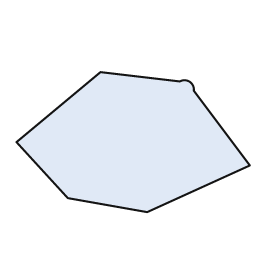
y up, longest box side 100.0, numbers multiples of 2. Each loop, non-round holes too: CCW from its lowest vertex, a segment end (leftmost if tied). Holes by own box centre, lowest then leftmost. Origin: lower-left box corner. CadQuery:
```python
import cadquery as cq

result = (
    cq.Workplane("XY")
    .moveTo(56.0, 0.0)
    .lineTo(100.0, 20.0)
    .lineTo(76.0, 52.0)
    .threePointArc((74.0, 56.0), (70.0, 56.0))
    .lineTo(36.0, 60.0)
    .lineTo(0.0, 30.0)
    .lineTo(22.0, 6.0)
    .close()
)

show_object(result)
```